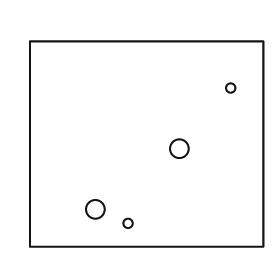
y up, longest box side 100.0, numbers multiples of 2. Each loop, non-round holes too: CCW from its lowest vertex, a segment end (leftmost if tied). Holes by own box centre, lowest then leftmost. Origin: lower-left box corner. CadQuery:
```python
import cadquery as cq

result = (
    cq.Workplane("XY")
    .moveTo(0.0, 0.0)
    .lineTo(100.0, 0.0)
    .lineTo(100.0, 88.0)
    .lineTo(0.0, 88.0)
    .close()
    .moveTo(42.0, 10.0)
    .circle(2.0)
    .moveTo(28.0, 16.0)
    .circle(4.0)
    .moveTo(64.0, 42.0)
    .circle(4.0)
    .moveTo(86.0, 68.0)
    .circle(2.0)
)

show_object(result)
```